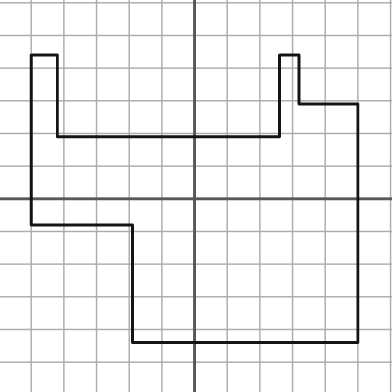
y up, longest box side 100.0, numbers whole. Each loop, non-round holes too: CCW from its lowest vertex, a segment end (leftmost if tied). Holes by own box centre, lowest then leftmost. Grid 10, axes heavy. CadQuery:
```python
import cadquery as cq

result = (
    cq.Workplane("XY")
    .moveTo(-19.0, -44.0)
    .lineTo(50.0, -44.0)
    .lineTo(50.0, 29.0)
    .lineTo(32.0, 29.0)
    .lineTo(32.0, 44.0)
    .lineTo(26.0, 44.0)
    .lineTo(26.0, 19.0)
    .lineTo(-42.0, 19.0)
    .lineTo(-42.0, 44.0)
    .lineTo(-50.0, 44.0)
    .lineTo(-50.0, -8.0)
    .lineTo(-19.0, -8.0)
    .close()
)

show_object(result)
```